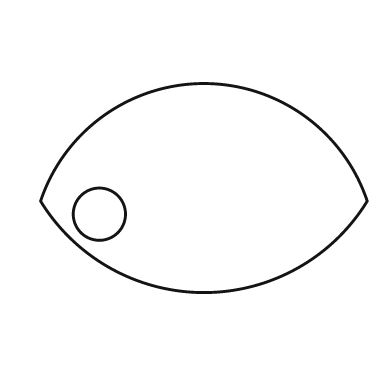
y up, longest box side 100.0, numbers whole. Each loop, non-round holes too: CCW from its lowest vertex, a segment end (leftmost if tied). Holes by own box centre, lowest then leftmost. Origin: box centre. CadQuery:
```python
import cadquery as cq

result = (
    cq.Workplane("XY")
    .moveTo(-50.0, -4.0)
    .threePointArc((0.0, -32.0), (50.0, -4.0))
    .threePointArc((0.0, 32.0), (-50.0, -4.0))
    .close()
    .moveTo(-32.0, -8.0)
    .circle(8.0)
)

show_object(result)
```